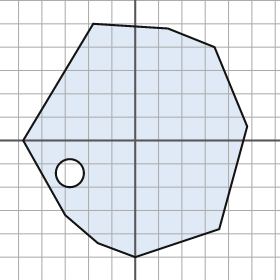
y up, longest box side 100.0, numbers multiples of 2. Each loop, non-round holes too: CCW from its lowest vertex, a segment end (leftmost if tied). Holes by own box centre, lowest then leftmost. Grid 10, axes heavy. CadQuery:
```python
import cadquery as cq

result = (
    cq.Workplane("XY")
    .moveTo(0.0, -50.0)
    .lineTo(36.0, -38.0)
    .lineTo(48.0, 6.0)
    .lineTo(34.0, 40.0)
    .lineTo(14.0, 48.0)
    .lineTo(-18.0, 50.0)
    .lineTo(-48.0, 0.0)
    .lineTo(-30.0, -32.0)
    .lineTo(-16.0, -44.0)
    .close()
    .moveTo(-28.0, -14.0)
    .circle(6.0)
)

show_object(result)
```